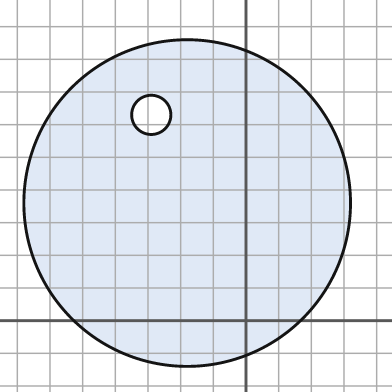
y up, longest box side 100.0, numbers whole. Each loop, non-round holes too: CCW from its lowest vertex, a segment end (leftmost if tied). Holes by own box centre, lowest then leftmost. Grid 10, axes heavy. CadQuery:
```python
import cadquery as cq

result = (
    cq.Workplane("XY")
    .moveTo(-18.0, 36.0)
    .circle(50.0)
    .moveTo(-29.0, 63.0)
    .circle(6.0)
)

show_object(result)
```